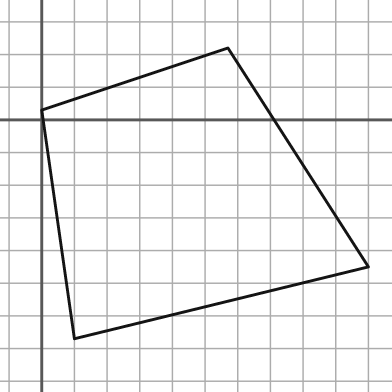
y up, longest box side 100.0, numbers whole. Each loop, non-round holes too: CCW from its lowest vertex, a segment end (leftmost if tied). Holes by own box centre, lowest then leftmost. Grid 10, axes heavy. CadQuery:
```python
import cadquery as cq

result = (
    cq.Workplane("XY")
    .moveTo(10.0, -67.0)
    .lineTo(100.0, -45.0)
    .lineTo(57.0, 22.0)
    .lineTo(0.0, 3.0)
    .close()
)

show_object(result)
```